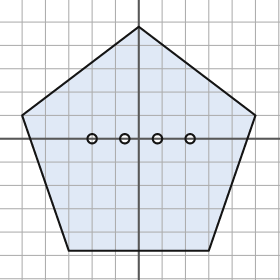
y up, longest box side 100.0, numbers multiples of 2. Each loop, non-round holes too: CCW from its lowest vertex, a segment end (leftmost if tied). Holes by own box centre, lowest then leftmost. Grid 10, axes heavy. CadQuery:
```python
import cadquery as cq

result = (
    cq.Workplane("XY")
    .moveTo(-30.0, -48.0)
    .lineTo(30.0, -48.0)
    .lineTo(50.0, 10.0)
    .lineTo(0.0, 48.0)
    .lineTo(-50.0, 10.0)
    .close()
    .moveTo(-20.0, 0.0)
    .circle(2.0)
    .moveTo(-6.0, 0.0)
    .circle(2.0)
    .moveTo(8.0, 0.0)
    .circle(2.0)
    .moveTo(22.0, 0.0)
    .circle(2.0)
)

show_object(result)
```